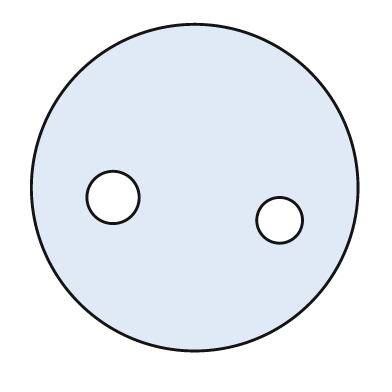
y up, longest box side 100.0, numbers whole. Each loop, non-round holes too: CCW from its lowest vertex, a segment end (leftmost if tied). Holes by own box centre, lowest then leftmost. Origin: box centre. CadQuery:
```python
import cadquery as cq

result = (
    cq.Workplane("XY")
    .moveTo(0.0, 0.0)
    .circle(50.0)
    .moveTo(26.0, -10.0)
    .circle(7.0)
    .moveTo(-25.0, -3.0)
    .circle(8.0)
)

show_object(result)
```